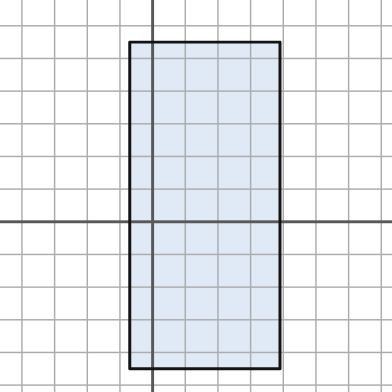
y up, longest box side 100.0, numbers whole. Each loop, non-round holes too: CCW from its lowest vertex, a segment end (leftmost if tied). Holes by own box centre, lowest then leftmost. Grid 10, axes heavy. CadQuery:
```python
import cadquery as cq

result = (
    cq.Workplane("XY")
    .moveTo(-7.0, -45.0)
    .lineTo(39.0, -45.0)
    .lineTo(39.0, 55.0)
    .lineTo(-7.0, 55.0)
    .close()
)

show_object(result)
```